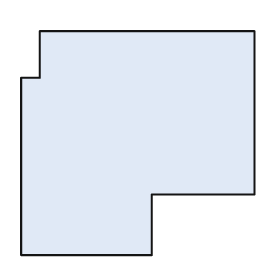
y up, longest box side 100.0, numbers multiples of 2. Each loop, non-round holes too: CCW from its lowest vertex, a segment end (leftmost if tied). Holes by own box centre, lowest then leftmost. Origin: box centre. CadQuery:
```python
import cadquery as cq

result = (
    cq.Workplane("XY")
    .moveTo(-50.0, -48.0)
    .lineTo(6.0, -48.0)
    .lineTo(6.0, -22.0)
    .lineTo(50.0, -22.0)
    .lineTo(50.0, 48.0)
    .lineTo(-42.0, 48.0)
    .lineTo(-42.0, 28.0)
    .lineTo(-50.0, 28.0)
    .close()
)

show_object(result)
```